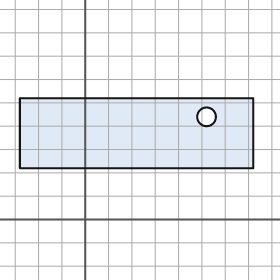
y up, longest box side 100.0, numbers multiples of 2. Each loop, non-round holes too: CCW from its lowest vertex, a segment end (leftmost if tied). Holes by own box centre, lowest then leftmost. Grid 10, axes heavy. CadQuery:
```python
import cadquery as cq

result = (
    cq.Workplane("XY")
    .moveTo(-28.0, 22.0)
    .lineTo(72.0, 22.0)
    .lineTo(72.0, 52.0)
    .lineTo(-28.0, 52.0)
    .close()
    .moveTo(52.0, 44.0)
    .circle(4.0)
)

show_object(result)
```